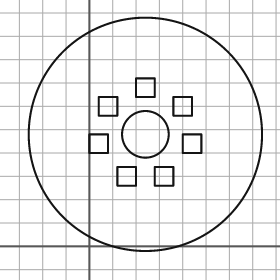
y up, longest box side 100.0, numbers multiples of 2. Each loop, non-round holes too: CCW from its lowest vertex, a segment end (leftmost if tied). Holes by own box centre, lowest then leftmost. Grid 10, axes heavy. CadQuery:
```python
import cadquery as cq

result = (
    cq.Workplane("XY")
    .moveTo(24.0, 48.0)
    .circle(50.0)
    .moveTo(12.0, 26.0)
    .lineTo(20.0, 26.0)
    .lineTo(20.0, 34.0)
    .lineTo(12.0, 34.0)
    .close()
    .moveTo(28.0, 26.0)
    .lineTo(36.0, 26.0)
    .lineTo(36.0, 34.0)
    .lineTo(28.0, 34.0)
    .close()
    .moveTo(0.0, 40.0)
    .lineTo(8.0, 40.0)
    .lineTo(8.0, 48.0)
    .lineTo(0.0, 48.0)
    .close()
    .moveTo(40.0, 40.0)
    .lineTo(48.0, 40.0)
    .lineTo(48.0, 48.0)
    .lineTo(40.0, 48.0)
    .close()
    .moveTo(24.0, 48.0)
    .circle(10.0)
    .moveTo(4.0, 56.0)
    .lineTo(12.0, 56.0)
    .lineTo(12.0, 64.0)
    .lineTo(4.0, 64.0)
    .close()
    .moveTo(36.0, 56.0)
    .lineTo(44.0, 56.0)
    .lineTo(44.0, 64.0)
    .lineTo(36.0, 64.0)
    .close()
    .moveTo(20.0, 64.0)
    .lineTo(28.0, 64.0)
    .lineTo(28.0, 72.0)
    .lineTo(20.0, 72.0)
    .close()
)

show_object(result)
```